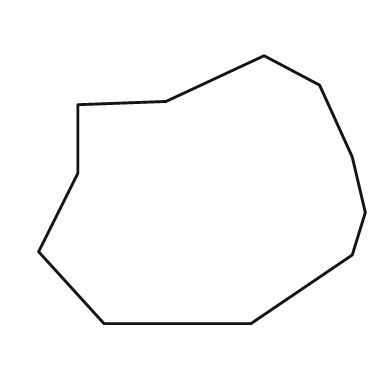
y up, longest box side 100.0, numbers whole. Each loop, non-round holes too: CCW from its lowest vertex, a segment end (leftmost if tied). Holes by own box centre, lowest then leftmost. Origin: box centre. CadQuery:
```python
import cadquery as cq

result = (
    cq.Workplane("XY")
    .moveTo(-30.0, -41.0)
    .lineTo(15.0, -41.0)
    .lineTo(46.0, -20.0)
    .lineTo(50.0, -7.0)
    .lineTo(46.0, 10.0)
    .lineTo(36.0, 32.0)
    .lineTo(19.0, 41.0)
    .lineTo(-11.0, 27.0)
    .lineTo(-38.0, 26.0)
    .lineTo(-38.0, 5.0)
    .lineTo(-50.0, -19.0)
    .close()
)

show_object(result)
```